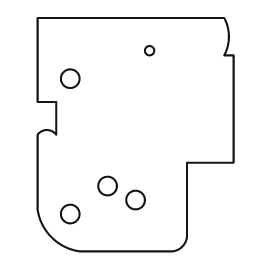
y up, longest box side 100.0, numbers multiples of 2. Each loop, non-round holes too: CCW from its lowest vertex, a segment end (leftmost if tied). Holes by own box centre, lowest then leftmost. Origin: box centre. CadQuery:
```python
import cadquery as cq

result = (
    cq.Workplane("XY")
    .moveTo(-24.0, -50.0)
    .lineTo(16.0, -50.0)
    .threePointArc((20.0, -48.0), (22.0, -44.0))
    .lineTo(22.0, -12.0)
    .lineTo(42.0, -12.0)
    .lineTo(42.0, 34.0)
    .lineTo(38.0, 34.0)
    .threePointArc((40.0, 42.0), (38.0, 50.0))
    .lineTo(-42.0, 50.0)
    .lineTo(-42.0, 14.0)
    .lineTo(-34.0, 14.0)
    .lineTo(-34.0, 0.0)
    .threePointArc((-38.0, 2.0), (-42.0, 0.0))
    .lineTo(-42.0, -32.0)
    .threePointArc((-36.0, -44.0), (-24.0, -50.0))
    .close()
    .moveTo(-28.0, -34.0)
    .circle(4.0)
    .moveTo(0.0, -28.0)
    .circle(4.0)
    .moveTo(-12.0, -22.0)
    .circle(4.0)
    .moveTo(-28.0, 24.0)
    .circle(4.0)
    .moveTo(6.0, 36.0)
    .circle(2.0)
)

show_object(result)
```